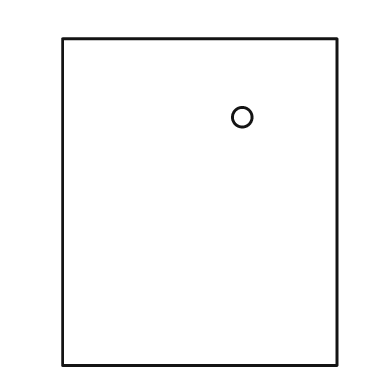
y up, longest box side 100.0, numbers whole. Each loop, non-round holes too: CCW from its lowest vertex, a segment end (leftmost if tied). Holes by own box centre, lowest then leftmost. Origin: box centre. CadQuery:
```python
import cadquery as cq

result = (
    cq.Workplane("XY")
    .moveTo(-42.0, -50.0)
    .lineTo(42.0, -50.0)
    .lineTo(42.0, 50.0)
    .lineTo(-42.0, 50.0)
    .close()
    .moveTo(13.0, 26.0)
    .circle(3.0)
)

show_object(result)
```